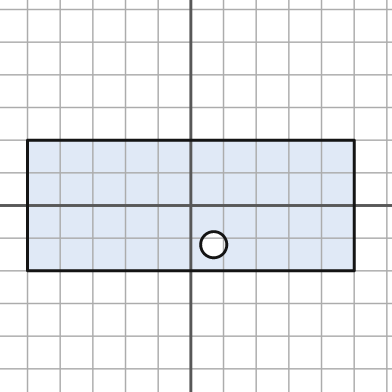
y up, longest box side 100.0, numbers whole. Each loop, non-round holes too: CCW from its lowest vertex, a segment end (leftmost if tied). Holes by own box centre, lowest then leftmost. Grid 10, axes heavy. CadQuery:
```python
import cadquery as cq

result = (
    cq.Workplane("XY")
    .moveTo(-50.0, -20.0)
    .lineTo(50.0, -20.0)
    .lineTo(50.0, 20.0)
    .lineTo(-50.0, 20.0)
    .close()
    .moveTo(7.0, -12.0)
    .circle(4.0)
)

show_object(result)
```